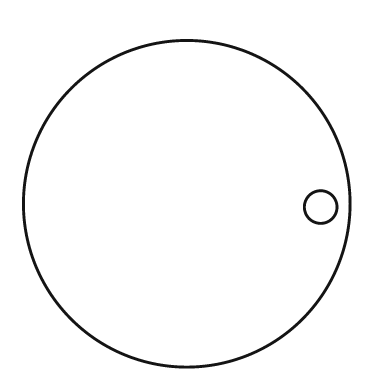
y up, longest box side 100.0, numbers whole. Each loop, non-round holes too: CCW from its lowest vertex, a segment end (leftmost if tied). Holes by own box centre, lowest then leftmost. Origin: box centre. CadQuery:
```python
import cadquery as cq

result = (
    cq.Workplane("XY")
    .moveTo(0.0, 0.0)
    .circle(50.0)
    .moveTo(41.0, -1.0)
    .circle(5.0)
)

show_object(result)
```